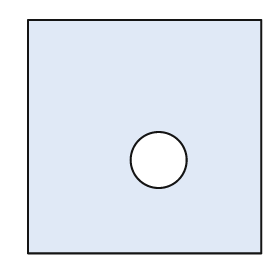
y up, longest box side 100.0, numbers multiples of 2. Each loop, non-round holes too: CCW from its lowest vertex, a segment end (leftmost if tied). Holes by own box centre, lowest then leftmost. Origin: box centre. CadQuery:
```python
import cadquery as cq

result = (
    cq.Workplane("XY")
    .moveTo(-50.0, -50.0)
    .lineTo(50.0, -50.0)
    .lineTo(50.0, 50.0)
    .lineTo(-50.0, 50.0)
    .close()
    .moveTo(6.0, -10.0)
    .circle(12.0)
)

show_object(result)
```